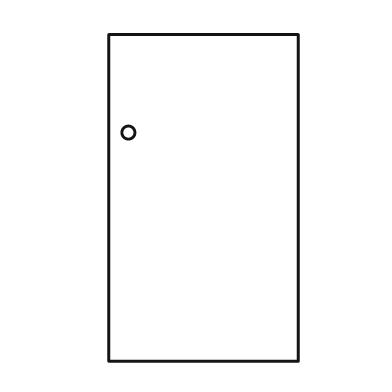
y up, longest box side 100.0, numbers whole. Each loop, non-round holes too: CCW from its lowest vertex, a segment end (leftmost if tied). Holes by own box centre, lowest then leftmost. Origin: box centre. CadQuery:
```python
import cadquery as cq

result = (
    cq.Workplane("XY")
    .moveTo(-29.0, -50.0)
    .lineTo(29.0, -50.0)
    .lineTo(29.0, 50.0)
    .lineTo(-29.0, 50.0)
    .close()
    .moveTo(-23.0, 20.0)
    .circle(2.0)
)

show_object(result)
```